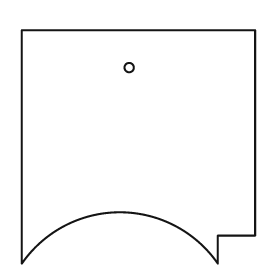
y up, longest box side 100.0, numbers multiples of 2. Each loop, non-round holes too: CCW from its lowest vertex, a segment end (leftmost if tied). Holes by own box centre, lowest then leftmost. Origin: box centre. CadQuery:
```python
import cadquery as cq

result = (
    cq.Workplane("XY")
    .moveTo(-50.0, -50.0)
    .threePointArc((-8.0, -28.0), (34.0, -50.0))
    .lineTo(34.0, -38.0)
    .lineTo(50.0, -38.0)
    .lineTo(50.0, 50.0)
    .lineTo(-50.0, 50.0)
    .close()
    .moveTo(-4.0, 34.0)
    .circle(2.0)
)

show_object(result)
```